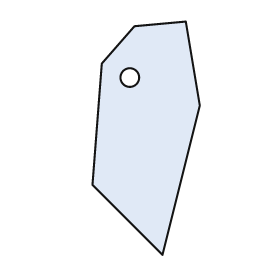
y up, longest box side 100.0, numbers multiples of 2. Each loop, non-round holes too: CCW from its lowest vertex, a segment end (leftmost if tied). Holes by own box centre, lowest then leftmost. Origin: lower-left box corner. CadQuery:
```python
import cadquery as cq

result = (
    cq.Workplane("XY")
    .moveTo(30.0, 0.0)
    .lineTo(46.0, 64.0)
    .lineTo(40.0, 100.0)
    .lineTo(18.0, 98.0)
    .lineTo(4.0, 82.0)
    .lineTo(0.0, 30.0)
    .close()
    .moveTo(16.0, 76.0)
    .circle(4.0)
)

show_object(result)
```